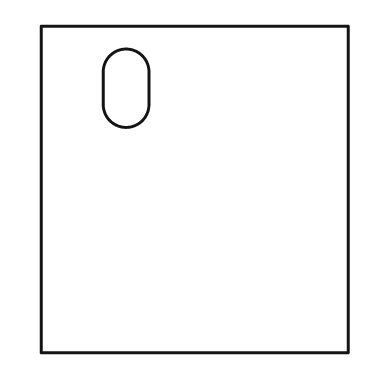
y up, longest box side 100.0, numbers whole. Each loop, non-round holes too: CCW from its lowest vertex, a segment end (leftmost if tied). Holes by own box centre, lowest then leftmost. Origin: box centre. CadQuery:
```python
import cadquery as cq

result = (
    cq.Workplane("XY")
    .moveTo(-47.0, -50.0)
    .lineTo(47.0, -50.0)
    .lineTo(47.0, 50.0)
    .lineTo(-47.0, 50.0)
    .close()
    .moveTo(-28.0, 26.0)
    .threePointArc((-21.0, 19.0), (-14.0, 26.0))
    .lineTo(-14.0, 36.0)
    .threePointArc((-21.0, 43.0), (-28.0, 36.0))
    .close()
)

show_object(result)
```